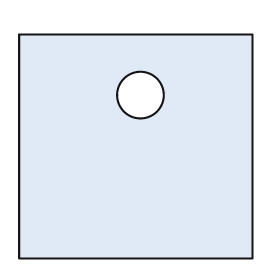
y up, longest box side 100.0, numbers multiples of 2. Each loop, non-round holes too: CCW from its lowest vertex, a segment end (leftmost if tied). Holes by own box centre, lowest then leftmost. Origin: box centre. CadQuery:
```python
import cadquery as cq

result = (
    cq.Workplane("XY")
    .moveTo(-50.0, -48.0)
    .lineTo(50.0, -48.0)
    .lineTo(50.0, 48.0)
    .lineTo(-50.0, 48.0)
    .close()
    .moveTo(2.0, 22.0)
    .circle(10.0)
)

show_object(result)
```